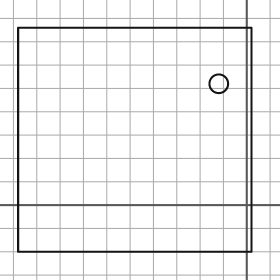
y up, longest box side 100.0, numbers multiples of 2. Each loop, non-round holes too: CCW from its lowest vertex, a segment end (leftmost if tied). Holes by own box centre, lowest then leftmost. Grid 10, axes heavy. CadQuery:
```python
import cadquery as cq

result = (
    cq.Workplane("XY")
    .moveTo(-98.0, -20.0)
    .lineTo(2.0, -20.0)
    .lineTo(2.0, 76.0)
    .lineTo(-98.0, 76.0)
    .close()
    .moveTo(-12.0, 52.0)
    .circle(4.0)
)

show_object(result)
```